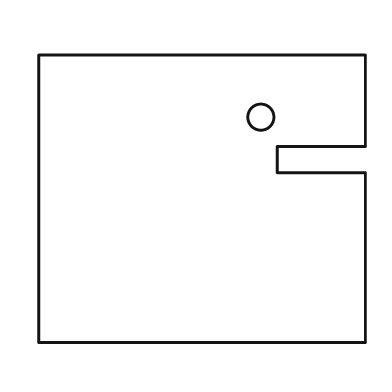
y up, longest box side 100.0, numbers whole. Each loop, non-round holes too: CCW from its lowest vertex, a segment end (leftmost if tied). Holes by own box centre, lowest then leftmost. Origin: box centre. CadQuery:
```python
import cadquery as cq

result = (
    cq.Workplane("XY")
    .moveTo(-50.0, -44.0)
    .lineTo(50.0, -44.0)
    .lineTo(50.0, 8.0)
    .lineTo(23.0, 8.0)
    .lineTo(23.0, 16.0)
    .lineTo(50.0, 16.0)
    .lineTo(50.0, 44.0)
    .lineTo(-50.0, 44.0)
    .close()
    .moveTo(18.0, 25.0)
    .circle(4.0)
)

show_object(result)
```